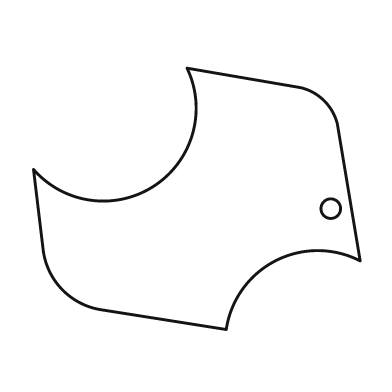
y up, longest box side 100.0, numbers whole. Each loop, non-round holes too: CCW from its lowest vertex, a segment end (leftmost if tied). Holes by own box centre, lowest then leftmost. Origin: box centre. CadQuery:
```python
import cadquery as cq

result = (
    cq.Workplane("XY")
    .moveTo(9.0, -40.0)
    .threePointArc((24.0, -19.0), (50.0, -19.0))
    .lineTo(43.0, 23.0)
    .threePointArc((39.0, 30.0), (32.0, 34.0))
    .lineTo(-3.0, 40.0)
    .threePointArc((-13.0, 4.0), (-50.0, 9.0))
    .lineTo(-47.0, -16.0)
    .threePointArc((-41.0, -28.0), (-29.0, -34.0))
    .close()
    .moveTo(41.0, -3.0)
    .circle(3.0)
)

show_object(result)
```